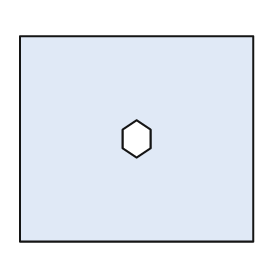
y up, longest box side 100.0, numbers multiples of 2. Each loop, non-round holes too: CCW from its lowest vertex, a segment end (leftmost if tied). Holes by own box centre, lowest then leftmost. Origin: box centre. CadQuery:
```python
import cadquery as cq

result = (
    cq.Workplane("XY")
    .moveTo(-50.0, -44.0)
    .lineTo(50.0, -44.0)
    .lineTo(50.0, 44.0)
    .lineTo(-50.0, 44.0)
    .close()
    .moveTo(0.0, -8.0)
    .lineTo(6.0, -4.0)
    .lineTo(6.0, 4.0)
    .lineTo(0.0, 8.0)
    .lineTo(-6.0, 4.0)
    .lineTo(-6.0, -4.0)
    .close()
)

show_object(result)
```